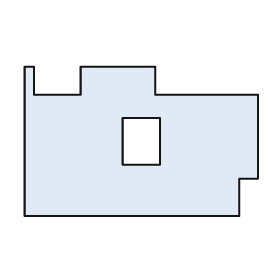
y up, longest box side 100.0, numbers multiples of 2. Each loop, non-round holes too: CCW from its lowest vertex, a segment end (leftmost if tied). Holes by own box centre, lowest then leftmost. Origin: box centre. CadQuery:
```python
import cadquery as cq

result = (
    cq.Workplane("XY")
    .moveTo(-50.0, -32.0)
    .lineTo(42.0, -32.0)
    .lineTo(42.0, -16.0)
    .lineTo(50.0, -16.0)
    .lineTo(50.0, 20.0)
    .lineTo(6.0, 20.0)
    .lineTo(6.0, 32.0)
    .lineTo(-26.0, 32.0)
    .lineTo(-26.0, 20.0)
    .lineTo(-46.0, 20.0)
    .lineTo(-46.0, 32.0)
    .lineTo(-50.0, 32.0)
    .close()
    .moveTo(-8.0, -10.0)
    .lineTo(8.0, -10.0)
    .lineTo(8.0, 10.0)
    .lineTo(-8.0, 10.0)
    .close()
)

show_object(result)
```